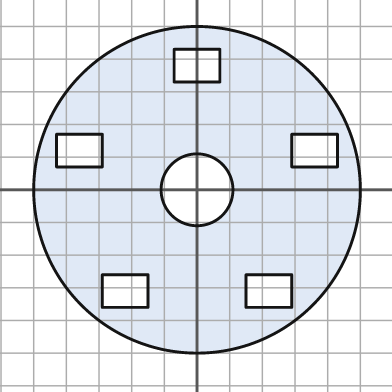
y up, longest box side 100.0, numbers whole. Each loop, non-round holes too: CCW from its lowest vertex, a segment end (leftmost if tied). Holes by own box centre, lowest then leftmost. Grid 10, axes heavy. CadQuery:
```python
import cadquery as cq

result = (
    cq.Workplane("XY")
    .moveTo(0.0, 0.0)
    .circle(50.0)
    .moveTo(-29.0, -36.0)
    .lineTo(-15.0, -36.0)
    .lineTo(-15.0, -26.0)
    .lineTo(-29.0, -26.0)
    .close()
    .moveTo(15.0, -36.0)
    .lineTo(29.0, -36.0)
    .lineTo(29.0, -26.0)
    .lineTo(15.0, -26.0)
    .close()
    .moveTo(0.0, 0.0)
    .circle(11.0)
    .moveTo(-43.0, 7.0)
    .lineTo(-29.0, 7.0)
    .lineTo(-29.0, 17.0)
    .lineTo(-43.0, 17.0)
    .close()
    .moveTo(29.0, 7.0)
    .lineTo(43.0, 7.0)
    .lineTo(43.0, 17.0)
    .lineTo(29.0, 17.0)
    .close()
    .moveTo(-7.0, 33.0)
    .lineTo(7.0, 33.0)
    .lineTo(7.0, 43.0)
    .lineTo(-7.0, 43.0)
    .close()
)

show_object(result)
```